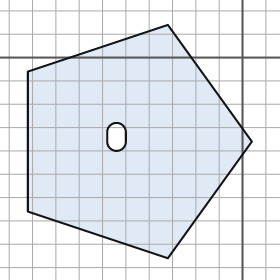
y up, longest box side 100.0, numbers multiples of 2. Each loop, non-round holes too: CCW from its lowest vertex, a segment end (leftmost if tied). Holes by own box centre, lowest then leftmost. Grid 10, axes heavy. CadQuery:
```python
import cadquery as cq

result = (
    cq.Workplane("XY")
    .moveTo(-32.0, -86.0)
    .lineTo(4.0, -36.0)
    .lineTo(-32.0, 14.0)
    .lineTo(-92.0, -6.0)
    .lineTo(-92.0, -66.0)
    .close()
    .moveTo(-58.0, -36.0)
    .threePointArc((-54.0, -40.0), (-50.0, -36.0))
    .lineTo(-50.0, -32.0)
    .threePointArc((-54.0, -28.0), (-58.0, -32.0))
    .close()
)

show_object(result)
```